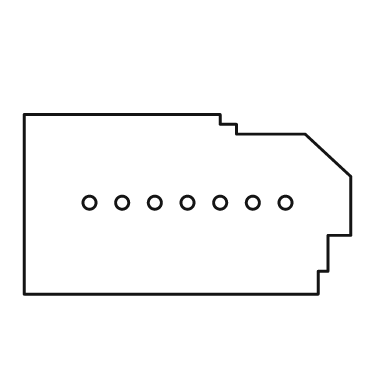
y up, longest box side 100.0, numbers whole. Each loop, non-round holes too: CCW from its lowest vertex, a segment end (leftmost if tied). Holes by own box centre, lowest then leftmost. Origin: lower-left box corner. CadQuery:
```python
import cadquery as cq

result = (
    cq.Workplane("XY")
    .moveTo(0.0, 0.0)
    .lineTo(90.0, 0.0)
    .lineTo(90.0, 7.0)
    .lineTo(93.0, 7.0)
    .lineTo(93.0, 18.0)
    .lineTo(100.0, 18.0)
    .lineTo(100.0, 36.0)
    .lineTo(86.0, 49.0)
    .lineTo(65.0, 49.0)
    .lineTo(65.0, 52.0)
    .lineTo(60.0, 52.0)
    .lineTo(60.0, 55.0)
    .lineTo(0.0, 55.0)
    .close()
    .moveTo(20.0, 28.0)
    .circle(2.0)
    .moveTo(30.0, 28.0)
    .circle(2.0)
    .moveTo(40.0, 28.0)
    .circle(2.0)
    .moveTo(50.0, 28.0)
    .circle(2.0)
    .moveTo(60.0, 28.0)
    .circle(2.0)
    .moveTo(70.0, 28.0)
    .circle(2.0)
    .moveTo(80.0, 28.0)
    .circle(2.0)
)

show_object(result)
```